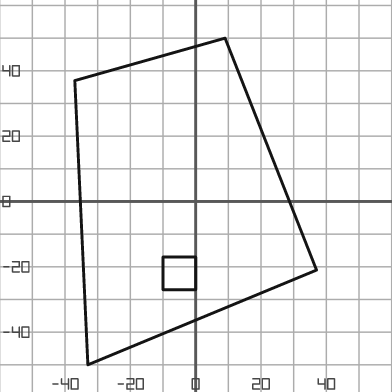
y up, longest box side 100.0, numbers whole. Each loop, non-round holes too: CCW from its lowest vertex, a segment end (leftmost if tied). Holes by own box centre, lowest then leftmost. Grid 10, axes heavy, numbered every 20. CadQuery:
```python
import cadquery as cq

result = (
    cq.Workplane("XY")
    .moveTo(-33.0, -50.0)
    .lineTo(37.0, -21.0)
    .lineTo(9.0, 50.0)
    .lineTo(-37.0, 37.0)
    .close()
    .moveTo(-10.0, -27.0)
    .lineTo(0.0, -27.0)
    .lineTo(0.0, -17.0)
    .lineTo(-10.0, -17.0)
    .close()
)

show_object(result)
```